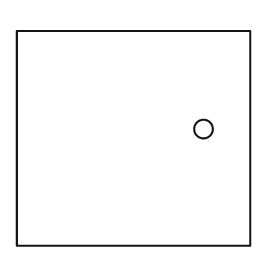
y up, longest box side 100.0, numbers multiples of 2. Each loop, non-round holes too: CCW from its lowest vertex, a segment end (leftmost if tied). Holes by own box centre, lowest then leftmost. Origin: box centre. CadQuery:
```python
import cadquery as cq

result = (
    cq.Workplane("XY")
    .moveTo(-50.0, -46.0)
    .lineTo(50.0, -46.0)
    .lineTo(50.0, 46.0)
    .lineTo(-50.0, 46.0)
    .close()
    .moveTo(30.0, 4.0)
    .circle(4.0)
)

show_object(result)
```